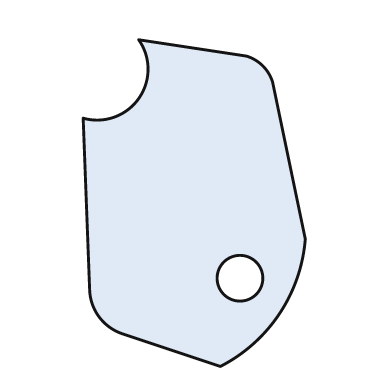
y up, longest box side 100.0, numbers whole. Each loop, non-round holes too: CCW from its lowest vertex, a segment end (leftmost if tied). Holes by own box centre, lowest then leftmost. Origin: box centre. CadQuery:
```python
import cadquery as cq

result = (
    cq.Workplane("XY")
    .moveTo(8.0, -50.0)
    .threePointArc((26.0, -34.0), (34.0, -11.0))
    .lineTo(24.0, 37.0)
    .threePointArc((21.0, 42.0), (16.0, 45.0))
    .lineTo(-17.0, 50.0)
    .threePointArc((-17.0, 32.0), (-34.0, 26.0))
    .lineTo(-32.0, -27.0)
    .threePointArc((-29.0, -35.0), (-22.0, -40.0))
    .close()
    .moveTo(14.0, -23.0)
    .circle(7.0)
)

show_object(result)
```